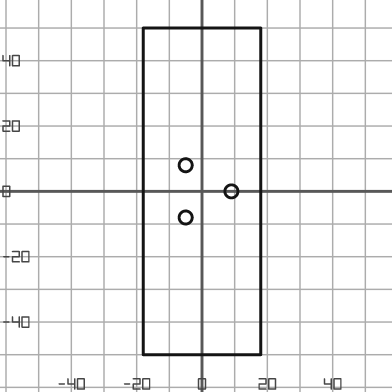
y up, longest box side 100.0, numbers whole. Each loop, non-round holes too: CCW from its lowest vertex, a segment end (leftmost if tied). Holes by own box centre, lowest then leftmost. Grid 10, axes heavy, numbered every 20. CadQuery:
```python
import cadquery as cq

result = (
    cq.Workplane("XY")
    .moveTo(-18.0, -50.0)
    .lineTo(18.0, -50.0)
    .lineTo(18.0, 50.0)
    .lineTo(-18.0, 50.0)
    .close()
    .moveTo(-5.0, -8.0)
    .circle(2.0)
    .moveTo(9.0, 0.0)
    .circle(2.0)
    .moveTo(-5.0, 8.0)
    .circle(2.0)
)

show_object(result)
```